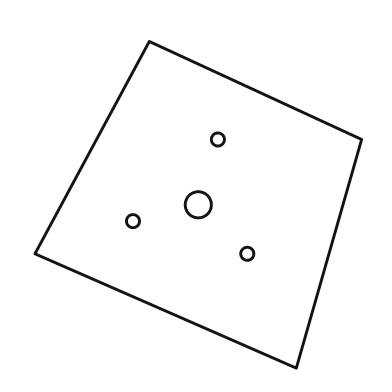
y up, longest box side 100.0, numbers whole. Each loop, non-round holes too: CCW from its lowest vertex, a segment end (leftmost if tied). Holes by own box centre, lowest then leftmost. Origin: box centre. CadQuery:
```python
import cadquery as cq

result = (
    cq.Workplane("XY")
    .moveTo(30.0, -50.0)
    .lineTo(50.0, 20.0)
    .lineTo(-15.0, 50.0)
    .lineTo(-50.0, -15.0)
    .close()
    .moveTo(15.0, -15.0)
    .circle(2.0)
    .moveTo(-20.0, -5.0)
    .circle(2.0)
    .moveTo(0.0, 0.0)
    .circle(4.0)
    .moveTo(6.0, 20.0)
    .circle(2.0)
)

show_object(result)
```